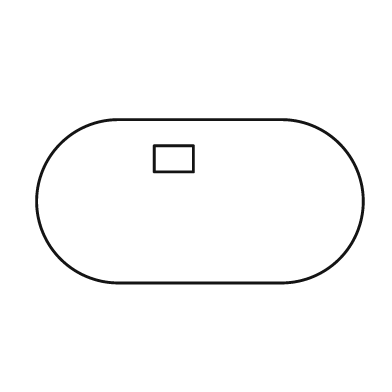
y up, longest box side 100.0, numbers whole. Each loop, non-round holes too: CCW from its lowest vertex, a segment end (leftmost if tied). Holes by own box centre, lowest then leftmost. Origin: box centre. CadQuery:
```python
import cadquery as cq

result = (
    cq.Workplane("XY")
    .moveTo(-25.0, -25.0)
    .lineTo(25.0, -25.0)
    .threePointArc((50.0, 0.0), (25.0, 25.0))
    .lineTo(-25.0, 25.0)
    .threePointArc((-50.0, 0.0), (-25.0, -25.0))
    .close()
    .moveTo(-14.0, 9.0)
    .lineTo(-2.0, 9.0)
    .lineTo(-2.0, 17.0)
    .lineTo(-14.0, 17.0)
    .close()
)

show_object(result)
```